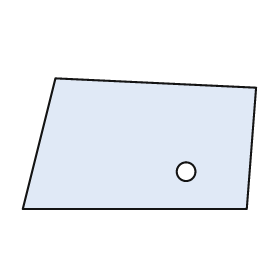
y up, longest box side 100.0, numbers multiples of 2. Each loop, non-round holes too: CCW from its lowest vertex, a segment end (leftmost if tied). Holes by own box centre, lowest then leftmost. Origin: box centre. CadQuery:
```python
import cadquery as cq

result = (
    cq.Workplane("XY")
    .moveTo(-50.0, -28.0)
    .lineTo(46.0, -28.0)
    .lineTo(50.0, 24.0)
    .lineTo(-36.0, 28.0)
    .close()
    .moveTo(20.0, -12.0)
    .circle(4.0)
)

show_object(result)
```